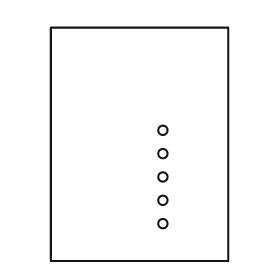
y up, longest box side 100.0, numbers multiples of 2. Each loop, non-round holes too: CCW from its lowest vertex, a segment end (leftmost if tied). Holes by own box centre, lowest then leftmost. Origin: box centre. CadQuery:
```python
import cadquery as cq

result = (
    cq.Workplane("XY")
    .moveTo(-38.0, -50.0)
    .lineTo(38.0, -50.0)
    .lineTo(38.0, 50.0)
    .lineTo(-38.0, 50.0)
    .close()
    .moveTo(10.0, -34.0)
    .circle(2.0)
    .moveTo(10.0, -24.0)
    .circle(2.0)
    .moveTo(10.0, -14.0)
    .circle(2.0)
    .moveTo(10.0, -4.0)
    .circle(2.0)
    .moveTo(10.0, 6.0)
    .circle(2.0)
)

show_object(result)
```